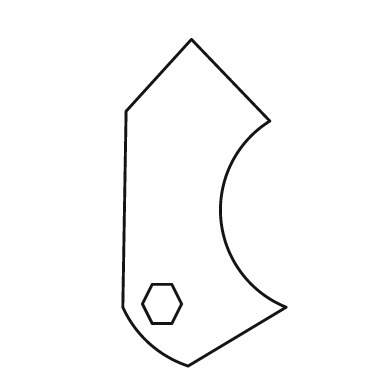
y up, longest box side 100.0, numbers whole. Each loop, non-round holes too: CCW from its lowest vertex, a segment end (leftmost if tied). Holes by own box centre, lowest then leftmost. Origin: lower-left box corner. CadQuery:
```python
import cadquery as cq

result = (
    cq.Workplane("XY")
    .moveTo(20.0, 0.0)
    .lineTo(50.0, 18.0)
    .threePointArc((30.0, 45.0), (45.0, 75.0))
    .lineTo(21.0, 100.0)
    .lineTo(1.0, 78.0)
    .lineTo(0.0, 18.0)
    .threePointArc((8.0, 7.0), (20.0, 0.0))
    .close()
    .moveTo(9.0, 13.0)
    .lineTo(15.0, 13.0)
    .lineTo(18.0, 19.0)
    .lineTo(15.0, 25.0)
    .lineTo(9.0, 25.0)
    .lineTo(6.0, 19.0)
    .close()
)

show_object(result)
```